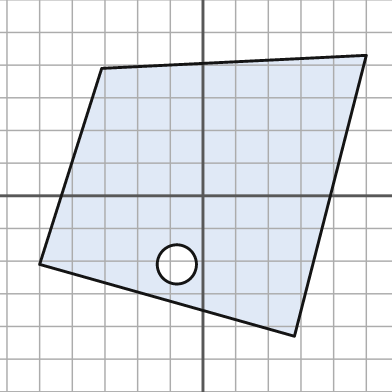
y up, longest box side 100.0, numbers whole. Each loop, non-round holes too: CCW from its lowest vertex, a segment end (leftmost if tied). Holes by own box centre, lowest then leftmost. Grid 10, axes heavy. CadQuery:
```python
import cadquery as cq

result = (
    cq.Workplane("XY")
    .moveTo(28.0, -43.0)
    .lineTo(50.0, 43.0)
    .lineTo(-31.0, 39.0)
    .lineTo(-50.0, -21.0)
    .close()
    .moveTo(-8.0, -21.0)
    .circle(6.0)
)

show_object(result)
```